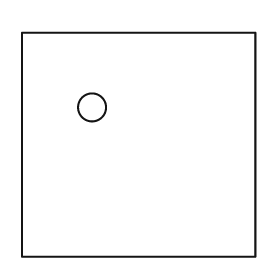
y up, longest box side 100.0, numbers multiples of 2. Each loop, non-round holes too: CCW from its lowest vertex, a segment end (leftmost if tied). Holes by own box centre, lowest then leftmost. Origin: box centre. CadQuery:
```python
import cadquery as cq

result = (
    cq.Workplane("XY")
    .moveTo(-50.0, -48.0)
    .lineTo(50.0, -48.0)
    .lineTo(50.0, 48.0)
    .lineTo(-50.0, 48.0)
    .close()
    .moveTo(-20.0, 16.0)
    .circle(6.0)
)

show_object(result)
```